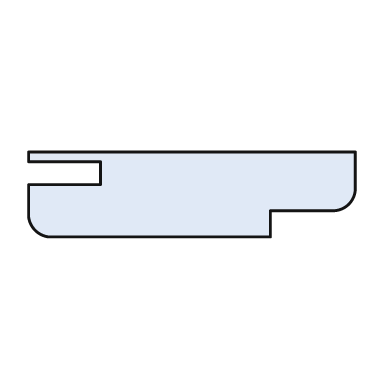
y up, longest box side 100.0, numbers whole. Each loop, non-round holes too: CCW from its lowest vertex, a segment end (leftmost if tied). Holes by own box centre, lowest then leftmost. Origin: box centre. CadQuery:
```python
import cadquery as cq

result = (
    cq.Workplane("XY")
    .moveTo(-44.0, -13.0)
    .lineTo(24.0, -13.0)
    .lineTo(24.0, -5.0)
    .lineTo(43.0, -5.0)
    .threePointArc((48.0, -3.0), (50.0, 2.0))
    .lineTo(50.0, 13.0)
    .lineTo(-50.0, 13.0)
    .lineTo(-50.0, 10.0)
    .lineTo(-28.0, 10.0)
    .lineTo(-28.0, 3.0)
    .lineTo(-50.0, 3.0)
    .lineTo(-50.0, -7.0)
    .threePointArc((-48.0, -11.0), (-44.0, -13.0))
    .close()
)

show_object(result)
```